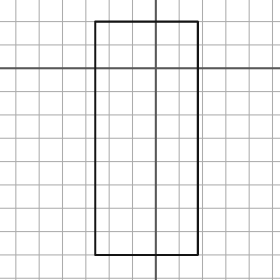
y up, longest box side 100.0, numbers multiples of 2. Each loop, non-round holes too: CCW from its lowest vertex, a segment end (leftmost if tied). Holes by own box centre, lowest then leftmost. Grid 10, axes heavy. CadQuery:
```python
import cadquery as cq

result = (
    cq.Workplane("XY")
    .moveTo(-26.0, -80.0)
    .lineTo(18.0, -80.0)
    .lineTo(18.0, 20.0)
    .lineTo(-26.0, 20.0)
    .close()
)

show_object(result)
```